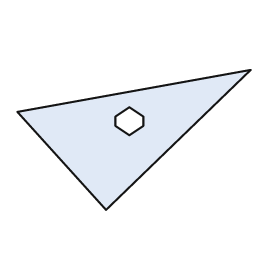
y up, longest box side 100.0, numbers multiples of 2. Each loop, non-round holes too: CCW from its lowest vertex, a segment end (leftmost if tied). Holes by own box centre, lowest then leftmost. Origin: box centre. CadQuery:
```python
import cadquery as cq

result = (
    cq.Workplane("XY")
    .moveTo(-12.0, -30.0)
    .lineTo(50.0, 30.0)
    .lineTo(-50.0, 12.0)
    .close()
    .moveTo(-2.0, 2.0)
    .lineTo(4.0, 6.0)
    .lineTo(4.0, 10.0)
    .lineTo(-2.0, 14.0)
    .lineTo(-8.0, 10.0)
    .lineTo(-8.0, 6.0)
    .close()
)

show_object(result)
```